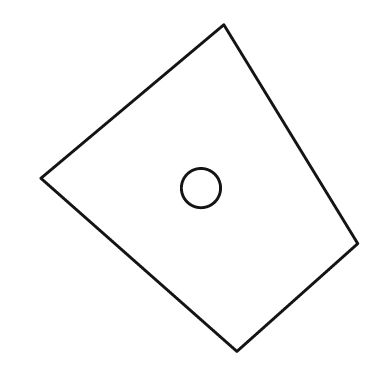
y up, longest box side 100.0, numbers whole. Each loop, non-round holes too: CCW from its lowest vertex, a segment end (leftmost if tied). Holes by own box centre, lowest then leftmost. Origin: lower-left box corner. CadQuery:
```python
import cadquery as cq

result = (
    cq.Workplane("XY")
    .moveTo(60.0, 0.0)
    .lineTo(97.0, 33.0)
    .lineTo(56.0, 100.0)
    .lineTo(0.0, 53.0)
    .close()
    .moveTo(49.0, 50.0)
    .circle(6.0)
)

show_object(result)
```